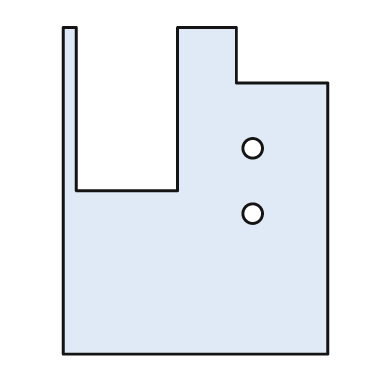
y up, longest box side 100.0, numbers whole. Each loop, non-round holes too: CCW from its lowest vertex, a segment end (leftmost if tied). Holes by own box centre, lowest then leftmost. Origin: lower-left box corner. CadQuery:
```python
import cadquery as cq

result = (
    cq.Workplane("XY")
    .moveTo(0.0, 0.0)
    .lineTo(81.0, 0.0)
    .lineTo(81.0, 83.0)
    .lineTo(53.0, 83.0)
    .lineTo(53.0, 100.0)
    .lineTo(35.0, 100.0)
    .lineTo(35.0, 50.0)
    .lineTo(4.0, 50.0)
    .lineTo(4.0, 100.0)
    .lineTo(0.0, 100.0)
    .close()
    .moveTo(58.0, 43.0)
    .circle(3.0)
    .moveTo(58.0, 63.0)
    .circle(3.0)
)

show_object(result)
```